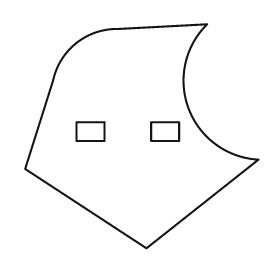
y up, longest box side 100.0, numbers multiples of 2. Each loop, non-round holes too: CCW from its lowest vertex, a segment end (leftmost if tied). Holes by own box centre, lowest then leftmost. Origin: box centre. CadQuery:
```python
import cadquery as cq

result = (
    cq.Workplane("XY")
    .moveTo(2.0, -48.0)
    .lineTo(50.0, -10.0)
    .threePointArc((20.0, 12.0), (28.0, 48.0))
    .lineTo(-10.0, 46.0)
    .threePointArc((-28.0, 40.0), (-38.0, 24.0))
    .lineTo(-50.0, -14.0)
    .close()
    .moveTo(-28.0, -2.0)
    .lineTo(-16.0, -2.0)
    .lineTo(-16.0, 6.0)
    .lineTo(-28.0, 6.0)
    .close()
    .moveTo(4.0, -2.0)
    .lineTo(16.0, -2.0)
    .lineTo(16.0, 6.0)
    .lineTo(4.0, 6.0)
    .close()
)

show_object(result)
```